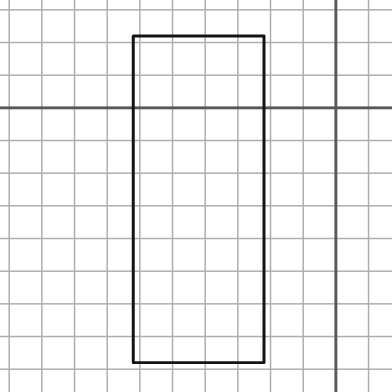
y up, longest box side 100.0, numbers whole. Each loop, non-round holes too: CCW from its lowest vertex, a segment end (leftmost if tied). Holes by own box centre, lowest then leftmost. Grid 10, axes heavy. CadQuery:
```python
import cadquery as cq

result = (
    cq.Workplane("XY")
    .moveTo(-62.0, -78.0)
    .lineTo(-22.0, -78.0)
    .lineTo(-22.0, 22.0)
    .lineTo(-62.0, 22.0)
    .close()
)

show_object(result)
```